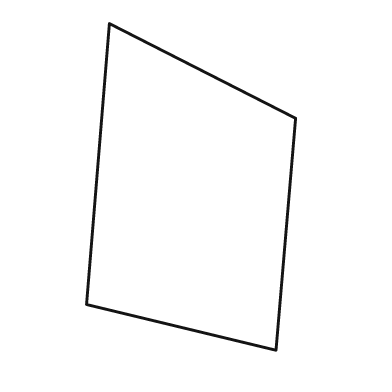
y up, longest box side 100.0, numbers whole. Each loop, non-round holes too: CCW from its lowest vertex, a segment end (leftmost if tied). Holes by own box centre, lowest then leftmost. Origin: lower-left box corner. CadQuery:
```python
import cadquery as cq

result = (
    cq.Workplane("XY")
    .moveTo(58.0, 0.0)
    .lineTo(64.0, 71.0)
    .lineTo(7.0, 100.0)
    .lineTo(0.0, 14.0)
    .close()
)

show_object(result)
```